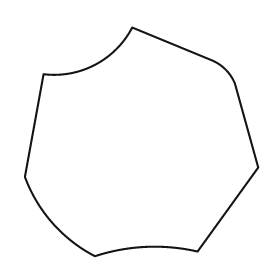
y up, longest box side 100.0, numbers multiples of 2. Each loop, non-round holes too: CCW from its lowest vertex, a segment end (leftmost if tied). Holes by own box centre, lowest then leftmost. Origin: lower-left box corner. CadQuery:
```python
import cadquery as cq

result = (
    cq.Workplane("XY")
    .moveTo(30.0, 0.0)
    .threePointArc((52.0, 4.0), (74.0, 2.0))
    .lineTo(100.0, 38.0)
    .lineTo(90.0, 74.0)
    .threePointArc((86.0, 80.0), (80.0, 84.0))
    .lineTo(46.0, 98.0)
    .threePointArc((30.0, 82.0), (8.0, 78.0))
    .lineTo(0.0, 34.0)
    .threePointArc((12.0, 14.0), (30.0, 0.0))
    .close()
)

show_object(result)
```